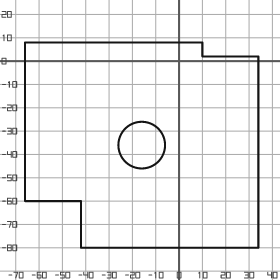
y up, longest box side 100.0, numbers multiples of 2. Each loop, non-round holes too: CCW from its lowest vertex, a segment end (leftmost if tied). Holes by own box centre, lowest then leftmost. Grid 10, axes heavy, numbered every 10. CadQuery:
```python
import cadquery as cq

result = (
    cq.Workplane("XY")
    .moveTo(-42.0, -80.0)
    .lineTo(34.0, -80.0)
    .lineTo(34.0, 2.0)
    .lineTo(10.0, 2.0)
    .lineTo(10.0, 8.0)
    .lineTo(-66.0, 8.0)
    .lineTo(-66.0, -60.0)
    .lineTo(-42.0, -60.0)
    .close()
    .moveTo(-16.0, -36.0)
    .circle(10.0)
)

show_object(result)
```